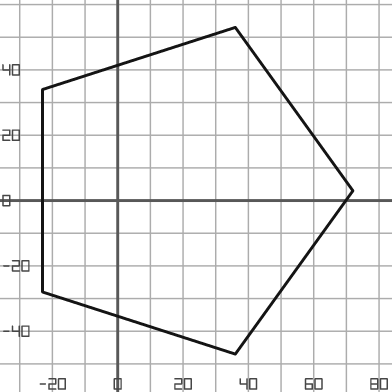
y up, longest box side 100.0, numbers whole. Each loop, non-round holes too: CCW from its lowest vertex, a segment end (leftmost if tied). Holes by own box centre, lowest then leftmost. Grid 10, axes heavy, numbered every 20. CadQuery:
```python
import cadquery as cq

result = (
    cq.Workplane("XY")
    .moveTo(36.0, -47.0)
    .lineTo(72.0, 3.0)
    .lineTo(36.0, 53.0)
    .lineTo(-23.0, 34.0)
    .lineTo(-23.0, -28.0)
    .close()
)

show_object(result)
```